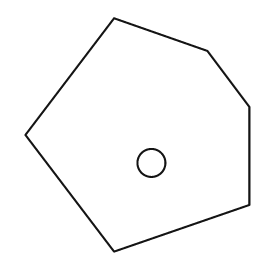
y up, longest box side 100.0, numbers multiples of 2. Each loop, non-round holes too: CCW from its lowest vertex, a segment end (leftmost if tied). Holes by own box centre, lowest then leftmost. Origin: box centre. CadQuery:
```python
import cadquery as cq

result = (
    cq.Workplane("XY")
    .moveTo(-10.0, -50.0)
    .lineTo(48.0, -30.0)
    .lineTo(48.0, 12.0)
    .lineTo(30.0, 36.0)
    .lineTo(-10.0, 50.0)
    .lineTo(-48.0, 0.0)
    .close()
    .moveTo(6.0, -12.0)
    .circle(6.0)
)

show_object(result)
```